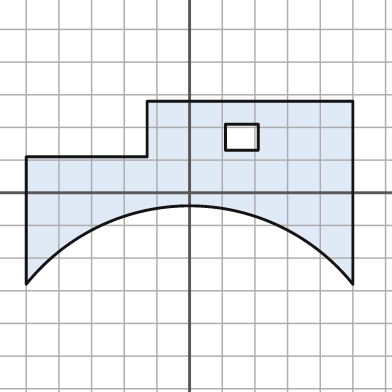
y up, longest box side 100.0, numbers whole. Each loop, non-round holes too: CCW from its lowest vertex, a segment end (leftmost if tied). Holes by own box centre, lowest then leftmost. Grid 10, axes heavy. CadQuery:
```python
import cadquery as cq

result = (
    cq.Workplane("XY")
    .moveTo(-50.0, -28.0)
    .threePointArc((0.0, -4.0), (50.0, -28.0))
    .lineTo(50.0, 28.0)
    .lineTo(-13.0, 28.0)
    .lineTo(-13.0, 11.0)
    .lineTo(-50.0, 11.0)
    .close()
    .moveTo(11.0, 13.0)
    .lineTo(21.0, 13.0)
    .lineTo(21.0, 21.0)
    .lineTo(11.0, 21.0)
    .close()
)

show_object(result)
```